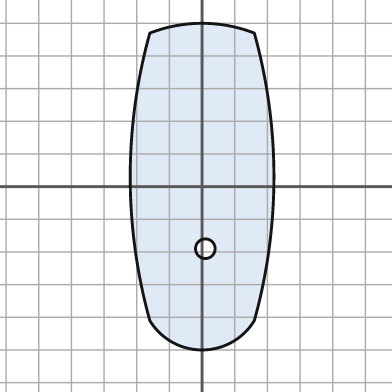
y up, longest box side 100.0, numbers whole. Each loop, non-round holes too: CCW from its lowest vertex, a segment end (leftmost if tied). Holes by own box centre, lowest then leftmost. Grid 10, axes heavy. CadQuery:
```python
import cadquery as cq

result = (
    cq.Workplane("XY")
    .moveTo(-16.0, -41.0)
    .threePointArc((0.0, -50.0), (16.0, -41.0))
    .threePointArc((22.0, 3.0), (16.0, 47.0))
    .threePointArc((0.0, 50.0), (-16.0, 47.0))
    .threePointArc((-22.0, 3.0), (-16.0, -41.0))
    .close()
    .moveTo(1.0, -19.0)
    .circle(3.0)
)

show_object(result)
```